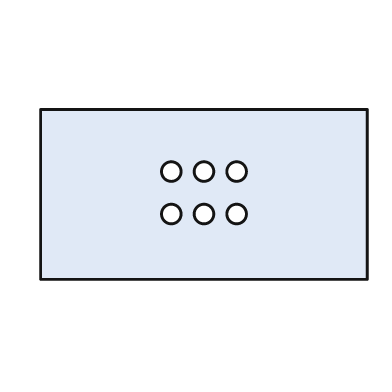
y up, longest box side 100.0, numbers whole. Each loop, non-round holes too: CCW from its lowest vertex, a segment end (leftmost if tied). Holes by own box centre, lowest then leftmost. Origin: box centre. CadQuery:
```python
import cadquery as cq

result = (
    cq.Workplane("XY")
    .moveTo(-50.0, -26.0)
    .lineTo(50.0, -26.0)
    .lineTo(50.0, 26.0)
    .lineTo(-50.0, 26.0)
    .close()
    .moveTo(-10.0, -6.0)
    .circle(3.0)
    .moveTo(0.0, -6.0)
    .circle(3.0)
    .moveTo(10.0, -6.0)
    .circle(3.0)
    .moveTo(-10.0, 7.0)
    .circle(3.0)
    .moveTo(0.0, 7.0)
    .circle(3.0)
    .moveTo(10.0, 7.0)
    .circle(3.0)
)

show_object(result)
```